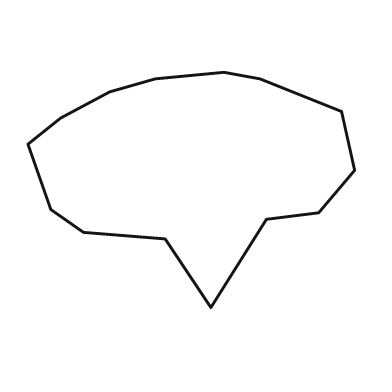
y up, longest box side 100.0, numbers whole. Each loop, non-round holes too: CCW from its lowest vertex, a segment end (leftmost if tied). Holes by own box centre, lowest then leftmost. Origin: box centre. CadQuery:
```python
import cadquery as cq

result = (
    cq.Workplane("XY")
    .moveTo(6.0, -36.0)
    .lineTo(23.0, -9.0)
    .lineTo(39.0, -7.0)
    .lineTo(50.0, 6.0)
    .lineTo(46.0, 24.0)
    .lineTo(21.0, 34.0)
    .lineTo(10.0, 36.0)
    .lineTo(-11.0, 34.0)
    .lineTo(-25.0, 30.0)
    .lineTo(-40.0, 22.0)
    .lineTo(-50.0, 14.0)
    .lineTo(-43.0, -6.0)
    .lineTo(-33.0, -13.0)
    .lineTo(-8.0, -15.0)
    .close()
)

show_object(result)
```